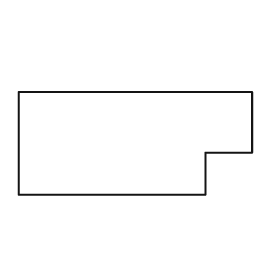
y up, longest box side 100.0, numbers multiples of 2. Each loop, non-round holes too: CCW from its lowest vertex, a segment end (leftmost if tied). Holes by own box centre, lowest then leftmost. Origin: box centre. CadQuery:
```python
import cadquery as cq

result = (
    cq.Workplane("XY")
    .moveTo(-50.0, -22.0)
    .lineTo(30.0, -22.0)
    .lineTo(30.0, -4.0)
    .lineTo(50.0, -4.0)
    .lineTo(50.0, 22.0)
    .lineTo(-50.0, 22.0)
    .close()
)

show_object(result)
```